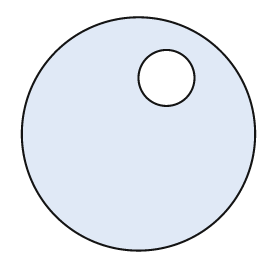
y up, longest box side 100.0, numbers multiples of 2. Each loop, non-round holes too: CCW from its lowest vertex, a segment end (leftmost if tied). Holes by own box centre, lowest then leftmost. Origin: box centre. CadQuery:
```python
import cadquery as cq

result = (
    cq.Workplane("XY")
    .moveTo(0.0, 0.0)
    .circle(50.0)
    .moveTo(12.0, 24.0)
    .circle(12.0)
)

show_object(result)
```